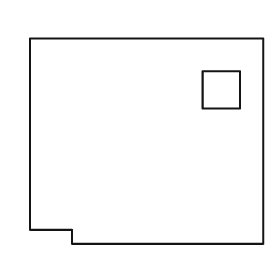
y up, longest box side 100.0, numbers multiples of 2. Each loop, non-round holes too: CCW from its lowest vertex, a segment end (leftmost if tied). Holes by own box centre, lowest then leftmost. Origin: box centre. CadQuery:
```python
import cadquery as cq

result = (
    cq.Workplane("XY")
    .moveTo(-32.0, -44.0)
    .lineTo(50.0, -44.0)
    .lineTo(50.0, 44.0)
    .lineTo(-50.0, 44.0)
    .lineTo(-50.0, -38.0)
    .lineTo(-32.0, -38.0)
    .close()
    .moveTo(24.0, 14.0)
    .lineTo(40.0, 14.0)
    .lineTo(40.0, 30.0)
    .lineTo(24.0, 30.0)
    .close()
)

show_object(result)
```